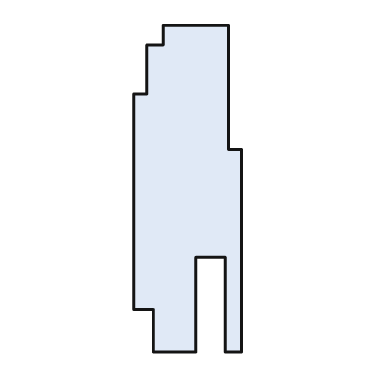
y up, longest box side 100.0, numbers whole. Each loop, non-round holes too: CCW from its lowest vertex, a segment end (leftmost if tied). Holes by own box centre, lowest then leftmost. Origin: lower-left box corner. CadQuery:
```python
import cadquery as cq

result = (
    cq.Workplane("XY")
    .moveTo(6.0, 0.0)
    .lineTo(19.0, 0.0)
    .lineTo(19.0, 29.0)
    .lineTo(28.0, 29.0)
    .lineTo(28.0, 0.0)
    .lineTo(33.0, 0.0)
    .lineTo(33.0, 62.0)
    .lineTo(29.0, 62.0)
    .lineTo(29.0, 100.0)
    .lineTo(9.0, 100.0)
    .lineTo(9.0, 94.0)
    .lineTo(4.0, 94.0)
    .lineTo(4.0, 79.0)
    .lineTo(0.0, 79.0)
    .lineTo(0.0, 13.0)
    .lineTo(6.0, 13.0)
    .close()
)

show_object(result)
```